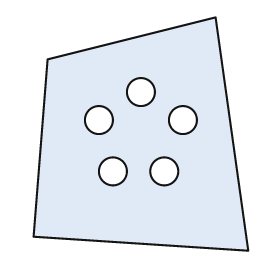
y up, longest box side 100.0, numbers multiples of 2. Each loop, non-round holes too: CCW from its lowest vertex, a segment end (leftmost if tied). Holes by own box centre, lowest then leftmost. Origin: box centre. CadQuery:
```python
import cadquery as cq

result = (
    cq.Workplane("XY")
    .moveTo(46.0, -50.0)
    .lineTo(32.0, 50.0)
    .lineTo(-40.0, 32.0)
    .lineTo(-46.0, -44.0)
    .close()
    .moveTo(-12.0, -16.0)
    .circle(6.0)
    .moveTo(10.0, -16.0)
    .circle(6.0)
    .moveTo(-18.0, 6.0)
    .circle(6.0)
    .moveTo(18.0, 6.0)
    .circle(6.0)
    .moveTo(0.0, 18.0)
    .circle(6.0)
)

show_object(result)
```